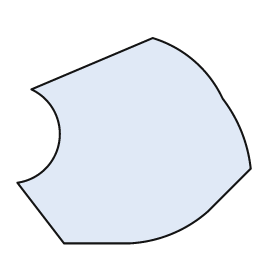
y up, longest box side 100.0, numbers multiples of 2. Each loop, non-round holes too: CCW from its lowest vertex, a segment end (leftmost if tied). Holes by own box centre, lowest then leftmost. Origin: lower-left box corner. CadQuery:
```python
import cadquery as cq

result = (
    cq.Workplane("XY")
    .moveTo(20.0, 0.0)
    .lineTo(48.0, 0.0)
    .threePointArc((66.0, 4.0), (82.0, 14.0))
    .lineTo(100.0, 32.0)
    .threePointArc((96.0, 48.0), (88.0, 62.0))
    .threePointArc((76.0, 78.0), (58.0, 88.0))
    .lineTo(6.0, 66.0)
    .threePointArc((18.0, 44.0), (0.0, 26.0))
    .close()
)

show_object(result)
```